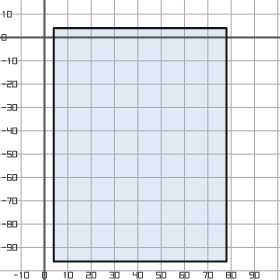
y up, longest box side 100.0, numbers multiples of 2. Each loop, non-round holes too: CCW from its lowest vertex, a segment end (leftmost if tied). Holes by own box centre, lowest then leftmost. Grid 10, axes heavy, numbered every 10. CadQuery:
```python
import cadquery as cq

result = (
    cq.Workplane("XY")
    .moveTo(4.0, -96.0)
    .lineTo(78.0, -96.0)
    .lineTo(78.0, 4.0)
    .lineTo(4.0, 4.0)
    .close()
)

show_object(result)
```